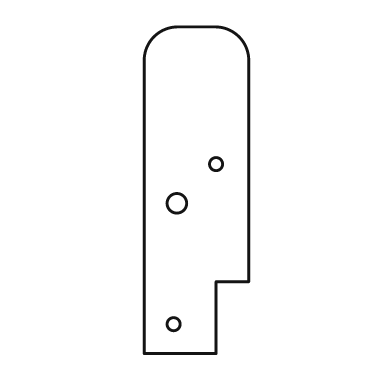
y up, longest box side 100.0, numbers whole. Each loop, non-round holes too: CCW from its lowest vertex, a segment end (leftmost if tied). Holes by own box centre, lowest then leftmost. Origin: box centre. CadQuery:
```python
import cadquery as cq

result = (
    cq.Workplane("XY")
    .moveTo(-16.0, -50.0)
    .lineTo(6.0, -50.0)
    .lineTo(6.0, -28.0)
    .lineTo(16.0, -28.0)
    .lineTo(16.0, 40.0)
    .threePointArc((13.0, 47.0), (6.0, 50.0))
    .lineTo(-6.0, 50.0)
    .threePointArc((-13.0, 47.0), (-16.0, 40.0))
    .close()
    .moveTo(-7.0, -41.0)
    .circle(2.0)
    .moveTo(-6.0, -4.0)
    .circle(3.0)
    .moveTo(6.0, 8.0)
    .circle(2.0)
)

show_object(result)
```